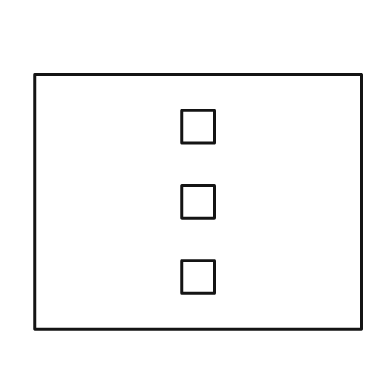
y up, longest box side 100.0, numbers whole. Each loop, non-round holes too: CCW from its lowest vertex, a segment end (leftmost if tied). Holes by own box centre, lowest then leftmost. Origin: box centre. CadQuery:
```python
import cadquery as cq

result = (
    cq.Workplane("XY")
    .moveTo(-50.0, -39.0)
    .lineTo(50.0, -39.0)
    .lineTo(50.0, 39.0)
    .lineTo(-50.0, 39.0)
    .close()
    .moveTo(-5.0, -28.0)
    .lineTo(5.0, -28.0)
    .lineTo(5.0, -18.0)
    .lineTo(-5.0, -18.0)
    .close()
    .moveTo(-5.0, -5.0)
    .lineTo(5.0, -5.0)
    .lineTo(5.0, 5.0)
    .lineTo(-5.0, 5.0)
    .close()
    .moveTo(-5.0, 18.0)
    .lineTo(5.0, 18.0)
    .lineTo(5.0, 28.0)
    .lineTo(-5.0, 28.0)
    .close()
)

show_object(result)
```